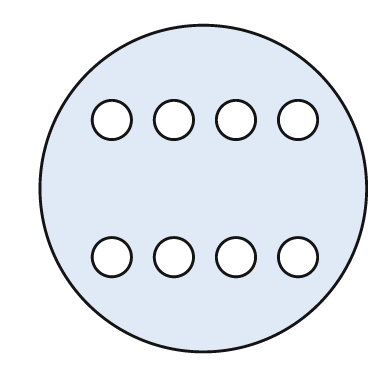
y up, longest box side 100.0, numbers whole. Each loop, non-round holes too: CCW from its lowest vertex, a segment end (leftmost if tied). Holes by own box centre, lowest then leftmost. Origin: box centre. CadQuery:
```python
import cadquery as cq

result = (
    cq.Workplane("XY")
    .moveTo(0.0, 0.0)
    .circle(50.0)
    .moveTo(-28.0, -21.0)
    .circle(6.0)
    .moveTo(-9.0, -21.0)
    .circle(6.0)
    .moveTo(10.0, -21.0)
    .circle(6.0)
    .moveTo(29.0, -21.0)
    .circle(6.0)
    .moveTo(-28.0, 21.0)
    .circle(6.0)
    .moveTo(-9.0, 21.0)
    .circle(6.0)
    .moveTo(10.0, 21.0)
    .circle(6.0)
    .moveTo(29.0, 21.0)
    .circle(6.0)
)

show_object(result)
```